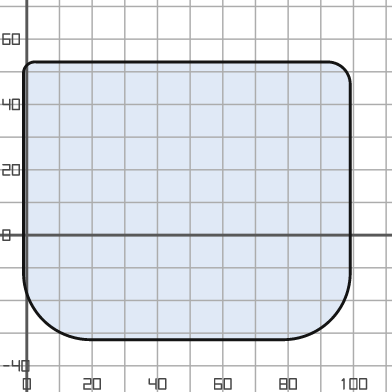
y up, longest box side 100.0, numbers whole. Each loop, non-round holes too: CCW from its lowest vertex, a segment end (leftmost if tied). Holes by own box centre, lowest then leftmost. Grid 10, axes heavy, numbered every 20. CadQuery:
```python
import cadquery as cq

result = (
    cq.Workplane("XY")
    .moveTo(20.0, -32.0)
    .lineTo(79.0, -32.0)
    .threePointArc((93.0, -26.0), (99.0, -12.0))
    .lineTo(99.0, 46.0)
    .threePointArc((97.0, 51.0), (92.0, 53.0))
    .lineTo(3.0, 53.0)
    .threePointArc((0.0, 52.0), (-1.0, 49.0))
    .lineTo(-1.0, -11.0)
    .threePointArc((5.0, -26.0), (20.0, -32.0))
    .close()
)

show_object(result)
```